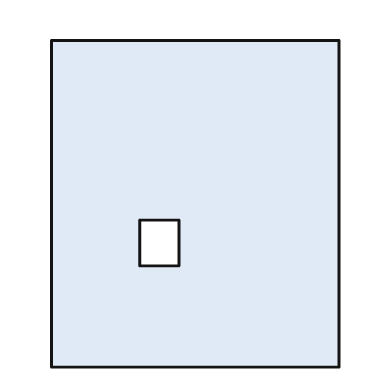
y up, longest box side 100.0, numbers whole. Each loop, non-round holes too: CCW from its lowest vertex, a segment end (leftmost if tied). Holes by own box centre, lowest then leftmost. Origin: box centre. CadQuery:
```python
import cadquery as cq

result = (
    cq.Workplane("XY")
    .moveTo(-44.0, -50.0)
    .lineTo(44.0, -50.0)
    .lineTo(44.0, 50.0)
    .lineTo(-44.0, 50.0)
    .close()
    .moveTo(-17.0, -19.0)
    .lineTo(-5.0, -19.0)
    .lineTo(-5.0, -5.0)
    .lineTo(-17.0, -5.0)
    .close()
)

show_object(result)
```